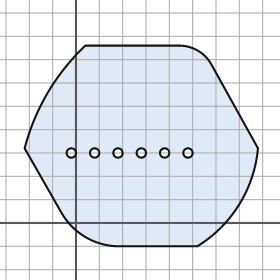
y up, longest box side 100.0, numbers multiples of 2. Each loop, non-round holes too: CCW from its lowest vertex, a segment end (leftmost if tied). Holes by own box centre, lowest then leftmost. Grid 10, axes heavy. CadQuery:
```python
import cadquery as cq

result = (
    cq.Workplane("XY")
    .moveTo(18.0, -10.0)
    .lineTo(52.0, -10.0)
    .threePointArc((70.0, 8.0), (78.0, 32.0))
    .lineTo(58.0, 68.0)
    .threePointArc((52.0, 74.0), (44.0, 76.0))
    .lineTo(4.0, 76.0)
    .threePointArc((-12.0, 56.0), (-22.0, 32.0))
    .lineTo(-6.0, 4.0)
    .threePointArc((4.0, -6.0), (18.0, -10.0))
    .close()
    .moveTo(-2.0, 30.0)
    .circle(2.0)
    .moveTo(8.0, 30.0)
    .circle(2.0)
    .moveTo(18.0, 30.0)
    .circle(2.0)
    .moveTo(28.0, 30.0)
    .circle(2.0)
    .moveTo(38.0, 30.0)
    .circle(2.0)
    .moveTo(48.0, 30.0)
    .circle(2.0)
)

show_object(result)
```